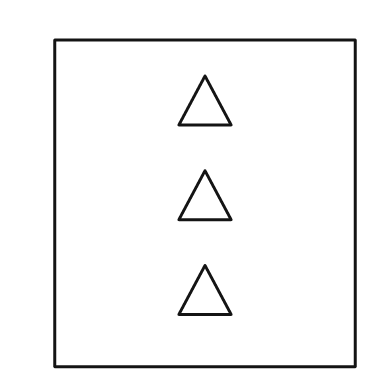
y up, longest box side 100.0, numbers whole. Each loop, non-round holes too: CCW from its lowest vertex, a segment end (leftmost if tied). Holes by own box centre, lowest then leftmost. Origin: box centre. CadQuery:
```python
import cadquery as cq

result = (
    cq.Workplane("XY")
    .moveTo(-46.0, -50.0)
    .lineTo(46.0, -50.0)
    .lineTo(46.0, 50.0)
    .lineTo(-46.0, 50.0)
    .close()
    .moveTo(-8.0, -34.0)
    .lineTo(8.0, -34.0)
    .lineTo(0.0, -19.0)
    .close()
    .moveTo(-8.0, -5.0)
    .lineTo(8.0, -5.0)
    .lineTo(0.0, 10.0)
    .close()
    .moveTo(-8.0, 24.0)
    .lineTo(8.0, 24.0)
    .lineTo(0.0, 39.0)
    .close()
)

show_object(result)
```